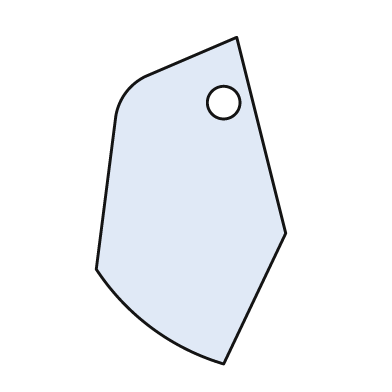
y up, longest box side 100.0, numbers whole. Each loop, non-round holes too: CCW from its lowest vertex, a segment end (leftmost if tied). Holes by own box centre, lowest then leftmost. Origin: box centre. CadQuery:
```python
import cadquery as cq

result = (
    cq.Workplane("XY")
    .moveTo(10.0, -50.0)
    .lineTo(29.0, -10.0)
    .lineTo(14.0, 50.0)
    .lineTo(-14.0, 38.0)
    .threePointArc((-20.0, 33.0), (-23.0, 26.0))
    .lineTo(-29.0, -21.0)
    .threePointArc((-12.0, -39.0), (10.0, -50.0))
    .close()
    .moveTo(10.0, 30.0)
    .circle(5.0)
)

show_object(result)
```